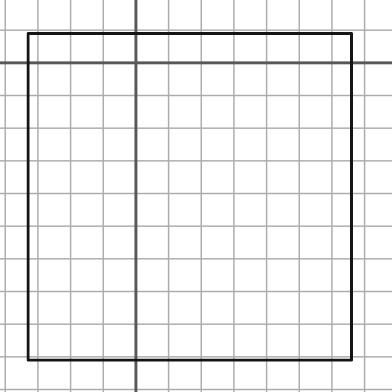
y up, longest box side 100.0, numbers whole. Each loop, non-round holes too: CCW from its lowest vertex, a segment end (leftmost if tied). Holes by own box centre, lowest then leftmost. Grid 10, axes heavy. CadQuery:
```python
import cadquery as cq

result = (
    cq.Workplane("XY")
    .moveTo(-33.0, -91.0)
    .lineTo(66.0, -91.0)
    .lineTo(66.0, 9.0)
    .lineTo(-33.0, 9.0)
    .close()
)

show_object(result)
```